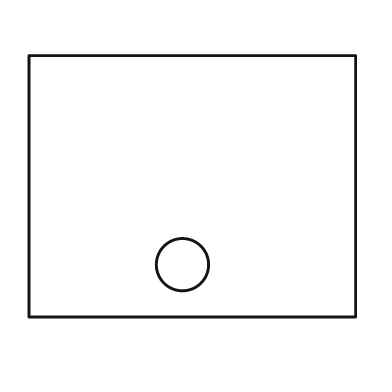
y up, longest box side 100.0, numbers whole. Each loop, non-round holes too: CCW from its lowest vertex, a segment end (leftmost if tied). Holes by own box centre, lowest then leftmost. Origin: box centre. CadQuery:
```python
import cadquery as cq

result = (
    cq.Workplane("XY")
    .moveTo(-50.0, -40.0)
    .lineTo(50.0, -40.0)
    .lineTo(50.0, 40.0)
    .lineTo(-50.0, 40.0)
    .close()
    .moveTo(-3.0, -24.0)
    .circle(8.0)
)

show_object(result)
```